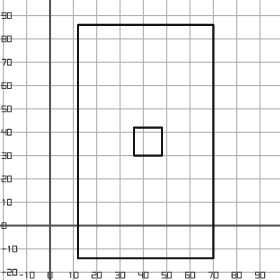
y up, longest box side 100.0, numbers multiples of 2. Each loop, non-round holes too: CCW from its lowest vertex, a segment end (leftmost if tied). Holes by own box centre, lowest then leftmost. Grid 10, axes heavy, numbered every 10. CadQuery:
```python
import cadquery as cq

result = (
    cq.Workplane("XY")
    .moveTo(12.0, -14.0)
    .lineTo(70.0, -14.0)
    .lineTo(70.0, 86.0)
    .lineTo(12.0, 86.0)
    .close()
    .moveTo(36.0, 30.0)
    .lineTo(48.0, 30.0)
    .lineTo(48.0, 42.0)
    .lineTo(36.0, 42.0)
    .close()
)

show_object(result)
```